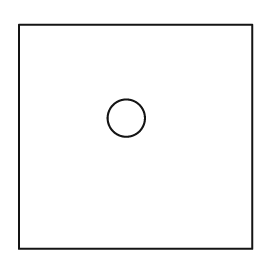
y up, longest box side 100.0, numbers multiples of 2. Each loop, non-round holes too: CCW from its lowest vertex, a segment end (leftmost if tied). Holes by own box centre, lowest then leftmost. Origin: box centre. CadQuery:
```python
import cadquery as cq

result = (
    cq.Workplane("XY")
    .moveTo(-50.0, -48.0)
    .lineTo(50.0, -48.0)
    .lineTo(50.0, 48.0)
    .lineTo(-50.0, 48.0)
    .close()
    .moveTo(-4.0, 8.0)
    .circle(8.0)
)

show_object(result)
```